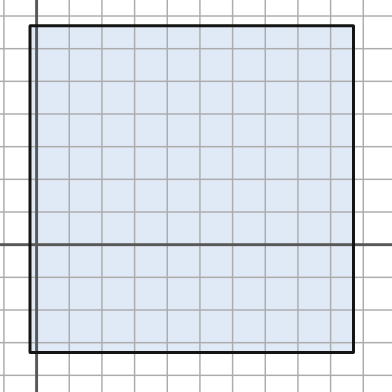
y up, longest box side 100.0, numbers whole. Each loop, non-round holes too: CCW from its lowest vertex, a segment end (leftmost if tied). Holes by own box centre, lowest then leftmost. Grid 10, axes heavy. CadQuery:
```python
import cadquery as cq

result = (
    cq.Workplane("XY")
    .moveTo(-2.0, -33.0)
    .lineTo(97.0, -33.0)
    .lineTo(97.0, 67.0)
    .lineTo(-2.0, 67.0)
    .close()
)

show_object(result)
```